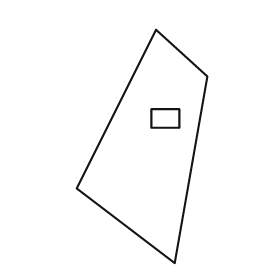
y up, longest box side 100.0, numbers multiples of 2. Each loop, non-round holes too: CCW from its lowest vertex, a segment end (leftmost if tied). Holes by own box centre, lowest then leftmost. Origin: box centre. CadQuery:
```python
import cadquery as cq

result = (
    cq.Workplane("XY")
    .moveTo(14.0, -50.0)
    .lineTo(28.0, 30.0)
    .lineTo(6.0, 50.0)
    .lineTo(-28.0, -18.0)
    .close()
    .moveTo(4.0, 8.0)
    .lineTo(16.0, 8.0)
    .lineTo(16.0, 16.0)
    .lineTo(4.0, 16.0)
    .close()
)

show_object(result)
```